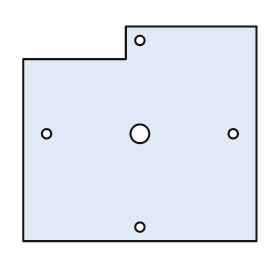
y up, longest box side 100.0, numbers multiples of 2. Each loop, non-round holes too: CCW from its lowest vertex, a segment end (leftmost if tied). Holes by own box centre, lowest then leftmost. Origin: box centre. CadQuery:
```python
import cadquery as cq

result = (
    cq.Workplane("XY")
    .moveTo(-50.0, -46.0)
    .lineTo(50.0, -46.0)
    .lineTo(50.0, 46.0)
    .lineTo(-6.0, 46.0)
    .lineTo(-6.0, 32.0)
    .lineTo(-50.0, 32.0)
    .close()
    .moveTo(0.0, -40.0)
    .circle(2.0)
    .moveTo(-40.0, 0.0)
    .circle(2.0)
    .moveTo(0.0, 0.0)
    .circle(4.0)
    .moveTo(40.0, 0.0)
    .circle(2.0)
    .moveTo(0.0, 40.0)
    .circle(2.0)
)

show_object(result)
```